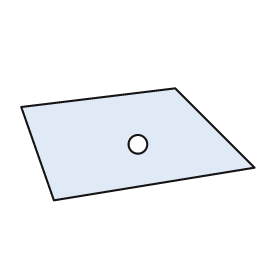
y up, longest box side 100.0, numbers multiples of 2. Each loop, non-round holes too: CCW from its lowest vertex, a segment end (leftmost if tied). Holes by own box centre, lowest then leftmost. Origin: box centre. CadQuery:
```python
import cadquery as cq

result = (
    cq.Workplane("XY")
    .moveTo(-36.0, -24.0)
    .lineTo(50.0, -10.0)
    .lineTo(16.0, 24.0)
    .lineTo(-50.0, 16.0)
    .close()
    .moveTo(0.0, 0.0)
    .circle(4.0)
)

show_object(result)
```